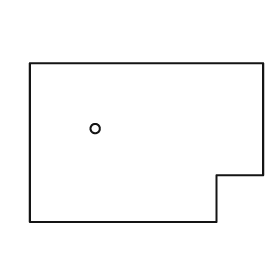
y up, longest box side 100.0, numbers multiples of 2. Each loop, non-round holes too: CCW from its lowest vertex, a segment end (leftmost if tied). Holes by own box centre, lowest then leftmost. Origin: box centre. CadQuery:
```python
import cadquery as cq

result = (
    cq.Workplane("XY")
    .moveTo(-50.0, -34.0)
    .lineTo(30.0, -34.0)
    .lineTo(30.0, -14.0)
    .lineTo(50.0, -14.0)
    .lineTo(50.0, 34.0)
    .lineTo(-50.0, 34.0)
    .close()
    .moveTo(-22.0, 6.0)
    .circle(2.0)
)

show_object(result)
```